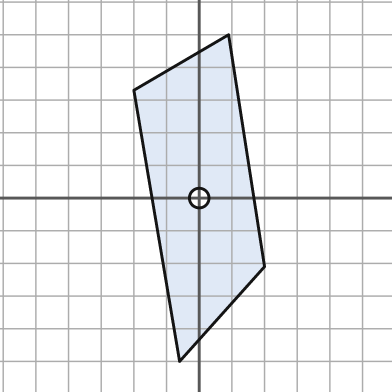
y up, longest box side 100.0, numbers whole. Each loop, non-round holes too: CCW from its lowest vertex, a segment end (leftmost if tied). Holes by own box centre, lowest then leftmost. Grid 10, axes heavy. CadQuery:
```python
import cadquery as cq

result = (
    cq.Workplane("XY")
    .moveTo(-6.0, -50.0)
    .lineTo(20.0, -21.0)
    .lineTo(9.0, 50.0)
    .lineTo(-20.0, 33.0)
    .close()
    .moveTo(0.0, 0.0)
    .circle(3.0)
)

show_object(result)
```